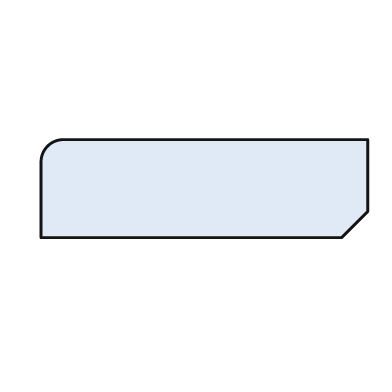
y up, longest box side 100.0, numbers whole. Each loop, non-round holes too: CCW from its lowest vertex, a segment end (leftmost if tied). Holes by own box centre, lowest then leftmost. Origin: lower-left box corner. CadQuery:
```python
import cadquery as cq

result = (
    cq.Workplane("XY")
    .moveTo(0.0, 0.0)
    .lineTo(92.0, 0.0)
    .lineTo(100.0, 8.0)
    .lineTo(100.0, 30.0)
    .lineTo(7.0, 30.0)
    .threePointArc((2.0, 28.0), (0.0, 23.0))
    .close()
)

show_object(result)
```